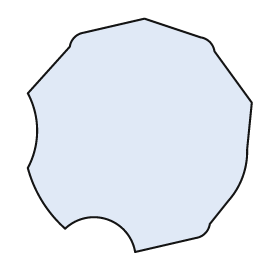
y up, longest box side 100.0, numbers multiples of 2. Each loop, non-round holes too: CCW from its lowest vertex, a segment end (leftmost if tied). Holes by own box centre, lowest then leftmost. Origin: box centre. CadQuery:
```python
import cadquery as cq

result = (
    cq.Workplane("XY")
    .moveTo(-2.0, -50.0)
    .lineTo(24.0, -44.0)
    .threePointArc((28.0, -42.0), (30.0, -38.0))
    .lineTo(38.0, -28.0)
    .threePointArc((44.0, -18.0), (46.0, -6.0))
    .lineTo(48.0, 14.0)
    .lineTo(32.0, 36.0)
    .threePointArc((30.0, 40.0), (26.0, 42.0))
    .lineTo(2.0, 50.0)
    .lineTo(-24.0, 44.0)
    .threePointArc((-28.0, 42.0), (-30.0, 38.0))
    .lineTo(-48.0, 18.0)
    .threePointArc((-44.0, 2.0), (-48.0, -14.0))
    .threePointArc((-42.0, -28.0), (-32.0, -40.0))
    .threePointArc((-14.0, -36.0), (-2.0, -50.0))
    .close()
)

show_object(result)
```